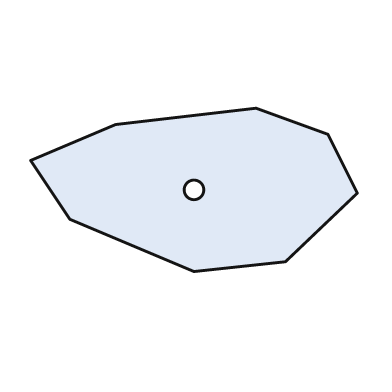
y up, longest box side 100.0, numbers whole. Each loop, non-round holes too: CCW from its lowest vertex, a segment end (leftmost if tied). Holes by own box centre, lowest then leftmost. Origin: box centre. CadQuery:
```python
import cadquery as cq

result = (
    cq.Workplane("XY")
    .moveTo(0.0, -25.0)
    .lineTo(28.0, -22.0)
    .lineTo(50.0, -1.0)
    .lineTo(41.0, 17.0)
    .lineTo(19.0, 25.0)
    .lineTo(-24.0, 20.0)
    .lineTo(-50.0, 9.0)
    .lineTo(-38.0, -9.0)
    .close()
    .moveTo(0.0, 0.0)
    .circle(3.0)
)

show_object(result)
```